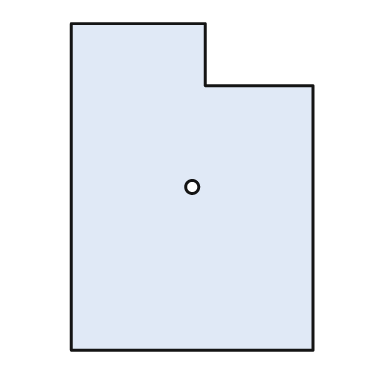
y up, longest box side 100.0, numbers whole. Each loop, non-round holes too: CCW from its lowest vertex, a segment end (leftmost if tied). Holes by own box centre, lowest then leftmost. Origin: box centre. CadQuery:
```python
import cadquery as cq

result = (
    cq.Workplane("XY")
    .moveTo(-37.0, -50.0)
    .lineTo(37.0, -50.0)
    .lineTo(37.0, 31.0)
    .lineTo(4.0, 31.0)
    .lineTo(4.0, 50.0)
    .lineTo(-37.0, 50.0)
    .close()
    .moveTo(0.0, 0.0)
    .circle(2.0)
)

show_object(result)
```